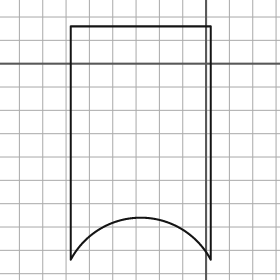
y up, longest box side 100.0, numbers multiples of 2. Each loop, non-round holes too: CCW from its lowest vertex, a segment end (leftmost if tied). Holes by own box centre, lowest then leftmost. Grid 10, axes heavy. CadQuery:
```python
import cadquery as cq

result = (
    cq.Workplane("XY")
    .moveTo(-58.0, -84.0)
    .threePointArc((-28.0, -66.0), (2.0, -84.0))
    .lineTo(2.0, 16.0)
    .lineTo(-58.0, 16.0)
    .close()
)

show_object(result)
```